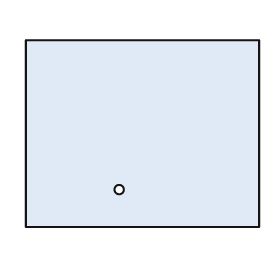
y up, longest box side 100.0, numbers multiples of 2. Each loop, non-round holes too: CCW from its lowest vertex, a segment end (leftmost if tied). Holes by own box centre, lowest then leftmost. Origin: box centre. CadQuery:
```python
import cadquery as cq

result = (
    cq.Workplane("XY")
    .moveTo(-50.0, -40.0)
    .lineTo(50.0, -40.0)
    .lineTo(50.0, 40.0)
    .lineTo(-50.0, 40.0)
    .close()
    .moveTo(-10.0, -24.0)
    .circle(2.0)
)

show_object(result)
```